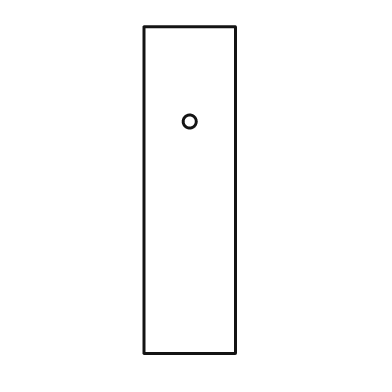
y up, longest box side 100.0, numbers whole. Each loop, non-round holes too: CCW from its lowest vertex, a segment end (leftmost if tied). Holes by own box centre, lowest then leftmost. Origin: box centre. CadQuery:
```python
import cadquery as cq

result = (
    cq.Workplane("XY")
    .moveTo(-14.0, -50.0)
    .lineTo(14.0, -50.0)
    .lineTo(14.0, 50.0)
    .lineTo(-14.0, 50.0)
    .close()
    .moveTo(0.0, 21.0)
    .circle(2.0)
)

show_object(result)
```